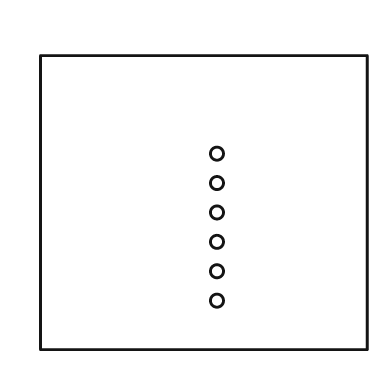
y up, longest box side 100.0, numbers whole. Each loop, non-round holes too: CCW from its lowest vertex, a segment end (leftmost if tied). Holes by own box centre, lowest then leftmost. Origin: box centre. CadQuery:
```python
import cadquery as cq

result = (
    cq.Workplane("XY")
    .moveTo(-50.0, -45.0)
    .lineTo(50.0, -45.0)
    .lineTo(50.0, 45.0)
    .lineTo(-50.0, 45.0)
    .close()
    .moveTo(4.0, -30.0)
    .circle(2.0)
    .moveTo(4.0, -21.0)
    .circle(2.0)
    .moveTo(4.0, -12.0)
    .circle(2.0)
    .moveTo(4.0, -3.0)
    .circle(2.0)
    .moveTo(4.0, 6.0)
    .circle(2.0)
    .moveTo(4.0, 15.0)
    .circle(2.0)
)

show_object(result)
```